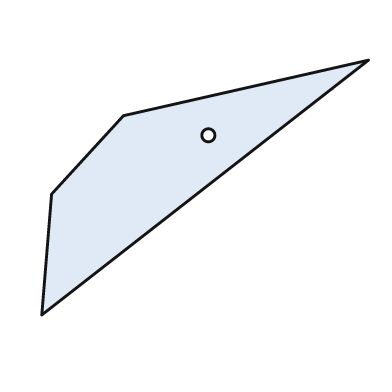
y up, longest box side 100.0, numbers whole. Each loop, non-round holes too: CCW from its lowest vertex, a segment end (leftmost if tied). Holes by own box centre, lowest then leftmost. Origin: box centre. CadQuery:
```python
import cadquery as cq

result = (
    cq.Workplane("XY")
    .moveTo(-50.0, -39.0)
    .lineTo(50.0, 39.0)
    .lineTo(-25.0, 22.0)
    .lineTo(-47.0, -2.0)
    .close()
    .moveTo(1.0, 16.0)
    .circle(2.0)
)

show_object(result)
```